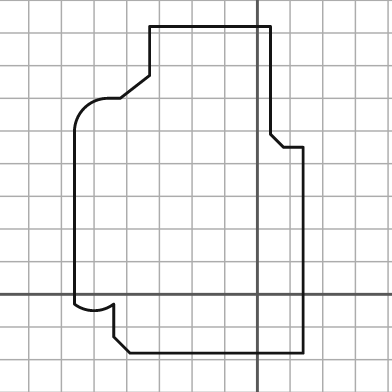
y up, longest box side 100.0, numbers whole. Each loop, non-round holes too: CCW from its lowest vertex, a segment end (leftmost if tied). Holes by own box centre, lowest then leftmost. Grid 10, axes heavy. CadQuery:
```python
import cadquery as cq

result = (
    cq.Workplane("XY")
    .moveTo(-39.0, -18.0)
    .lineTo(14.0, -18.0)
    .lineTo(14.0, 45.0)
    .lineTo(8.0, 45.0)
    .lineTo(4.0, 49.0)
    .lineTo(4.0, 82.0)
    .lineTo(-33.0, 82.0)
    .lineTo(-33.0, 67.0)
    .lineTo(-42.0, 60.0)
    .lineTo(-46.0, 60.0)
    .threePointArc((-53.0, 57.0), (-56.0, 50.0))
    .lineTo(-56.0, -3.0)
    .threePointArc((-50.0, -5.0), (-44.0, -3.0))
    .lineTo(-44.0, -13.0)
    .close()
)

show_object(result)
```